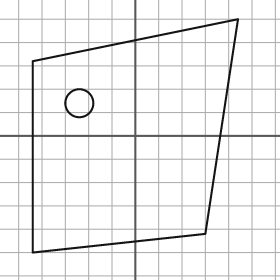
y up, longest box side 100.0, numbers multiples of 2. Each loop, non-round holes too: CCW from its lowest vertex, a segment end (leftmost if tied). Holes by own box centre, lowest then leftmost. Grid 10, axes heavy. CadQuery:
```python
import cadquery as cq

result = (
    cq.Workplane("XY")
    .moveTo(-44.0, -50.0)
    .lineTo(30.0, -42.0)
    .lineTo(44.0, 50.0)
    .lineTo(-44.0, 32.0)
    .close()
    .moveTo(-24.0, 14.0)
    .circle(6.0)
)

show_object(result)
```